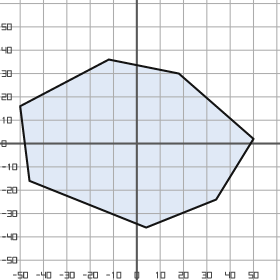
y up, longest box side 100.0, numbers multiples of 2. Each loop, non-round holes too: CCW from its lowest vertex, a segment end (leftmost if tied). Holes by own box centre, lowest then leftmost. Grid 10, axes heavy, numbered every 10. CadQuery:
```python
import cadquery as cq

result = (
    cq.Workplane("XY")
    .moveTo(4.0, -36.0)
    .lineTo(34.0, -24.0)
    .lineTo(50.0, 2.0)
    .lineTo(18.0, 30.0)
    .lineTo(-12.0, 36.0)
    .lineTo(-50.0, 16.0)
    .lineTo(-46.0, -16.0)
    .close()
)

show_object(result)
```